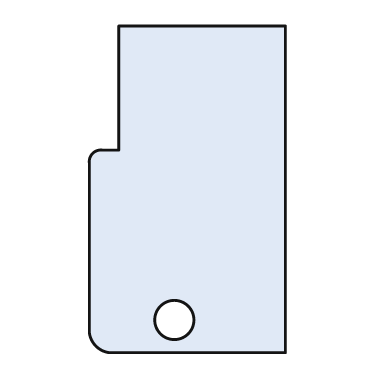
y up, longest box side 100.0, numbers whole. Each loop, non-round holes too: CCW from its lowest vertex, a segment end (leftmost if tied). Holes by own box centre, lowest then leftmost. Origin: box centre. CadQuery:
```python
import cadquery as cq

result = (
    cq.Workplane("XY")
    .moveTo(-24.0, -50.0)
    .lineTo(30.0, -50.0)
    .lineTo(30.0, 50.0)
    .lineTo(-21.0, 50.0)
    .lineTo(-21.0, 12.0)
    .lineTo(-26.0, 12.0)
    .threePointArc((-29.0, 11.0), (-30.0, 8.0))
    .lineTo(-30.0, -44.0)
    .threePointArc((-28.0, -48.0), (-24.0, -50.0))
    .close()
    .moveTo(-4.0, -40.0)
    .circle(6.0)
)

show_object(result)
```